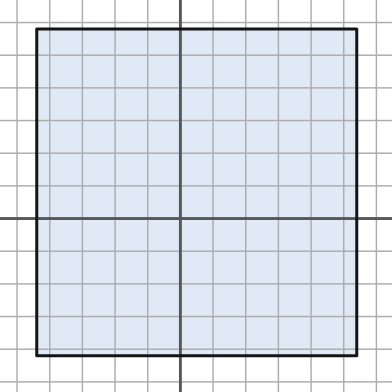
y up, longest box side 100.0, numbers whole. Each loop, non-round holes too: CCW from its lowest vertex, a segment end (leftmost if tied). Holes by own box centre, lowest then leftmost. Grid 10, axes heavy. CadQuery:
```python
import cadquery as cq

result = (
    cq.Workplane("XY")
    .moveTo(-44.0, -42.0)
    .lineTo(54.0, -42.0)
    .lineTo(54.0, 58.0)
    .lineTo(-44.0, 58.0)
    .close()
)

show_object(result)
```